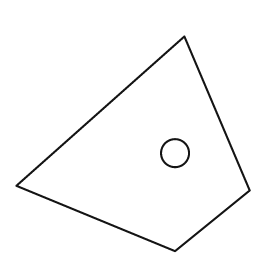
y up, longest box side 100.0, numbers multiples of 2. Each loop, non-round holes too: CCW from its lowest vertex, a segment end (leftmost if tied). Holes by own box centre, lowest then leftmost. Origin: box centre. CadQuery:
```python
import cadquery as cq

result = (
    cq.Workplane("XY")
    .moveTo(18.0, -46.0)
    .lineTo(50.0, -20.0)
    .lineTo(22.0, 46.0)
    .lineTo(-50.0, -18.0)
    .close()
    .moveTo(18.0, -4.0)
    .circle(6.0)
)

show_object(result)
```